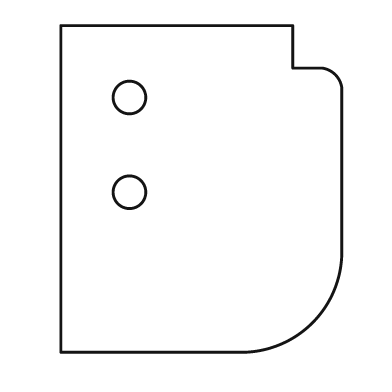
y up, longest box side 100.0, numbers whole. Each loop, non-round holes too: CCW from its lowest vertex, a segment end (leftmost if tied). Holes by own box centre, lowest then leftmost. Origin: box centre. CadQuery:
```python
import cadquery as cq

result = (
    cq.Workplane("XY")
    .moveTo(-43.0, -50.0)
    .lineTo(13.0, -50.0)
    .threePointArc((34.0, -41.0), (43.0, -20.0))
    .lineTo(43.0, 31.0)
    .threePointArc((41.0, 35.0), (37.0, 37.0))
    .lineTo(28.0, 37.0)
    .lineTo(28.0, 50.0)
    .lineTo(-43.0, 50.0)
    .close()
    .moveTo(-22.0, -1.0)
    .circle(5.0)
    .moveTo(-22.0, 28.0)
    .circle(5.0)
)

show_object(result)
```